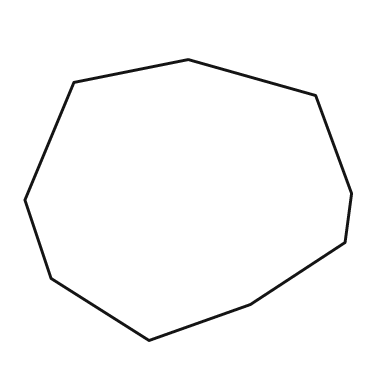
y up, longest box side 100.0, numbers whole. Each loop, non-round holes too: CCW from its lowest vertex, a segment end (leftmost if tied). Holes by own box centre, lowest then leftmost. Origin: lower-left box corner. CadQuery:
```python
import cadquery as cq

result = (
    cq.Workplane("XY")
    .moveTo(38.0, 0.0)
    .lineTo(69.0, 11.0)
    .lineTo(98.0, 30.0)
    .lineTo(100.0, 45.0)
    .lineTo(89.0, 75.0)
    .lineTo(50.0, 86.0)
    .lineTo(15.0, 79.0)
    .lineTo(0.0, 43.0)
    .lineTo(8.0, 19.0)
    .close()
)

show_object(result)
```